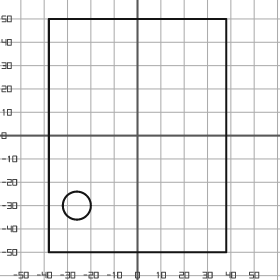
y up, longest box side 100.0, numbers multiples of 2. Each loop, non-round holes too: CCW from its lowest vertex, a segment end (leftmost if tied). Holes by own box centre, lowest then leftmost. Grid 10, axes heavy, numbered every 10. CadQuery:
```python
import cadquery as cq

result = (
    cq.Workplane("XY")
    .moveTo(-38.0, -50.0)
    .lineTo(38.0, -50.0)
    .lineTo(38.0, 50.0)
    .lineTo(-38.0, 50.0)
    .close()
    .moveTo(-26.0, -30.0)
    .circle(6.0)
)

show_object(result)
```